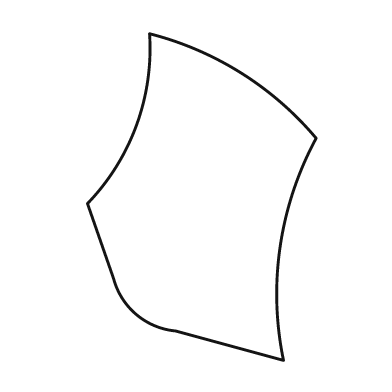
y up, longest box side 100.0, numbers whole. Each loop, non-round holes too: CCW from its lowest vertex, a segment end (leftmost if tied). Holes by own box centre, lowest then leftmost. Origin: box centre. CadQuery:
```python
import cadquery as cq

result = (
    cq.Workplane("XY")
    .moveTo(25.0, -50.0)
    .threePointArc((24.0, -15.0), (35.0, 18.0))
    .threePointArc((12.0, 38.0), (-16.0, 50.0))
    .threePointArc((-20.0, 22.0), (-35.0, -2.0))
    .lineTo(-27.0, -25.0)
    .threePointArc((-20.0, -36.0), (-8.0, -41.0))
    .close()
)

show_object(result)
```